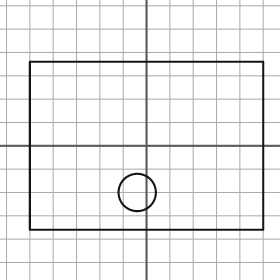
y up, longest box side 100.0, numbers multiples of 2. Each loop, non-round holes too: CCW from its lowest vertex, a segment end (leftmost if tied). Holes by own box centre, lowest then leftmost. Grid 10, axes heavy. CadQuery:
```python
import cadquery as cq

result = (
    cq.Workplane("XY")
    .moveTo(-50.0, -36.0)
    .lineTo(50.0, -36.0)
    .lineTo(50.0, 36.0)
    .lineTo(-50.0, 36.0)
    .close()
    .moveTo(-4.0, -20.0)
    .circle(8.0)
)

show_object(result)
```